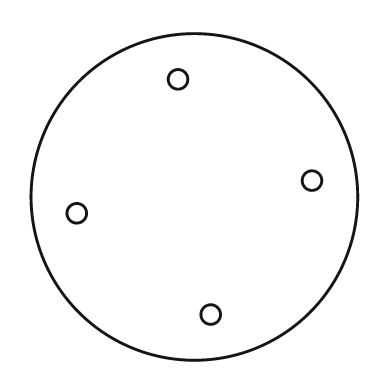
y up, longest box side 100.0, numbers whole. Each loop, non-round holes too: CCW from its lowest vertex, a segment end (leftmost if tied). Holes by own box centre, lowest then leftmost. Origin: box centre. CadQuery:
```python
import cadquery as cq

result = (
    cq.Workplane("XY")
    .moveTo(0.0, 0.0)
    .circle(50.0)
    .moveTo(5.0, -36.0)
    .circle(3.0)
    .moveTo(-36.0, -5.0)
    .circle(3.0)
    .moveTo(36.0, 5.0)
    .circle(3.0)
    .moveTo(-5.0, 36.0)
    .circle(3.0)
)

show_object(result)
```